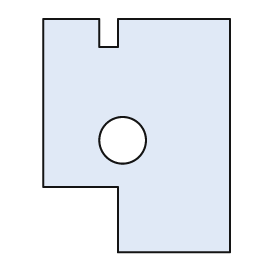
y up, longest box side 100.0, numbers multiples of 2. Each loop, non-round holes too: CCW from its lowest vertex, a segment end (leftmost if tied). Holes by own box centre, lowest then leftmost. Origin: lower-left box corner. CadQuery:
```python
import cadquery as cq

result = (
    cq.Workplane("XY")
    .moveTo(32.0, 0.0)
    .lineTo(80.0, 0.0)
    .lineTo(80.0, 100.0)
    .lineTo(32.0, 100.0)
    .lineTo(32.0, 88.0)
    .lineTo(24.0, 88.0)
    .lineTo(24.0, 100.0)
    .lineTo(0.0, 100.0)
    .lineTo(0.0, 28.0)
    .lineTo(32.0, 28.0)
    .close()
    .moveTo(34.0, 48.0)
    .circle(10.0)
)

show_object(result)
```